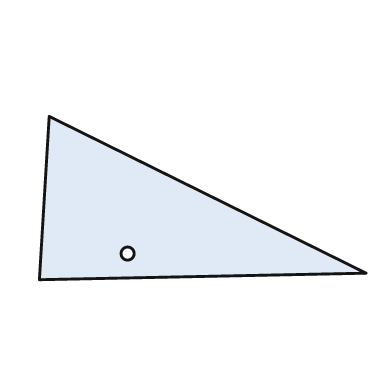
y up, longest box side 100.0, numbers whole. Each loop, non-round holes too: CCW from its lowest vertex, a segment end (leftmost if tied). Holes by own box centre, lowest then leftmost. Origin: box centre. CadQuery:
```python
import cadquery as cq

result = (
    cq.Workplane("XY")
    .moveTo(-50.0, -25.0)
    .lineTo(50.0, -23.0)
    .lineTo(-47.0, 25.0)
    .close()
    .moveTo(-23.0, -17.0)
    .circle(2.0)
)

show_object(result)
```